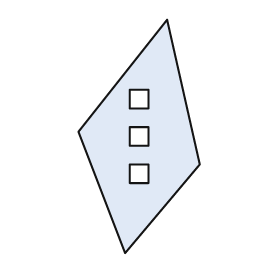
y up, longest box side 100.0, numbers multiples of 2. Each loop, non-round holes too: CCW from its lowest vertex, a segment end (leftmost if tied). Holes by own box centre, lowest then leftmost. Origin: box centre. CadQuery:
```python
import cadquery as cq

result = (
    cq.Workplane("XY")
    .moveTo(-6.0, -50.0)
    .lineTo(26.0, -12.0)
    .lineTo(12.0, 50.0)
    .lineTo(-26.0, 2.0)
    .close()
    .moveTo(-4.0, -20.0)
    .lineTo(4.0, -20.0)
    .lineTo(4.0, -12.0)
    .lineTo(-4.0, -12.0)
    .close()
    .moveTo(-4.0, -4.0)
    .lineTo(4.0, -4.0)
    .lineTo(4.0, 4.0)
    .lineTo(-4.0, 4.0)
    .close()
    .moveTo(-4.0, 12.0)
    .lineTo(4.0, 12.0)
    .lineTo(4.0, 20.0)
    .lineTo(-4.0, 20.0)
    .close()
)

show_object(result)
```